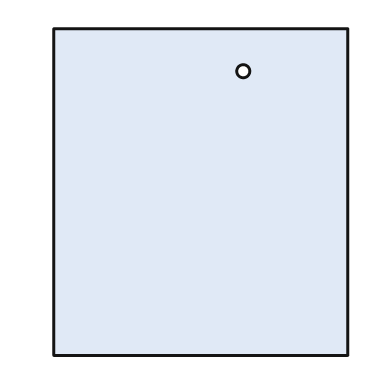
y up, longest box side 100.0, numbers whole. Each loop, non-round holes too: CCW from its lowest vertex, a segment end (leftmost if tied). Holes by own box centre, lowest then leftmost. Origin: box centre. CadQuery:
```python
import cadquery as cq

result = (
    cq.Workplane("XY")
    .moveTo(-45.0, -50.0)
    .lineTo(45.0, -50.0)
    .lineTo(45.0, 50.0)
    .lineTo(-45.0, 50.0)
    .close()
    .moveTo(13.0, 37.0)
    .circle(2.0)
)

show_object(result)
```